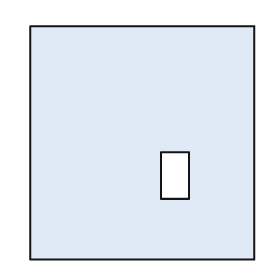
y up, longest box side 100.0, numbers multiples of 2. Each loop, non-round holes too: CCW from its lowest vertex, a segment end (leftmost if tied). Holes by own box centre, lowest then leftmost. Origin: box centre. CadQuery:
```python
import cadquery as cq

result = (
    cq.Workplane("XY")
    .moveTo(-48.0, -50.0)
    .lineTo(48.0, -50.0)
    .lineTo(48.0, 50.0)
    .lineTo(-48.0, 50.0)
    .close()
    .moveTo(8.0, -24.0)
    .lineTo(20.0, -24.0)
    .lineTo(20.0, -4.0)
    .lineTo(8.0, -4.0)
    .close()
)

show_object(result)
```